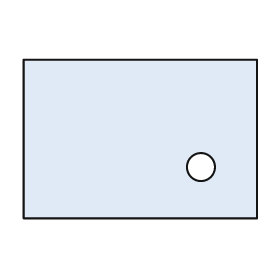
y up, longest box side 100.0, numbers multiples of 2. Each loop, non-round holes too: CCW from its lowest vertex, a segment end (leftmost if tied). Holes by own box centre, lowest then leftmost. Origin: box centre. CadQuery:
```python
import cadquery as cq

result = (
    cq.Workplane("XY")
    .moveTo(-50.0, -34.0)
    .lineTo(50.0, -34.0)
    .lineTo(50.0, 34.0)
    .lineTo(-50.0, 34.0)
    .close()
    .moveTo(26.0, -12.0)
    .circle(6.0)
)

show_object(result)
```